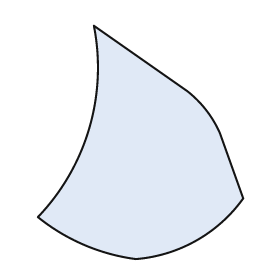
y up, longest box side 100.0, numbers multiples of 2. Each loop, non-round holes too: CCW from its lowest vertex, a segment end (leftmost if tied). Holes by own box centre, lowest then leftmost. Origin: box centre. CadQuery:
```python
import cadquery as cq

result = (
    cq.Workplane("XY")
    .moveTo(-2.0, -50.0)
    .threePointArc((24.0, -42.0), (44.0, -24.0))
    .lineTo(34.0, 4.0)
    .threePointArc((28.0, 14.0), (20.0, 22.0))
    .lineTo(-20.0, 50.0)
    .threePointArc((-22.0, 6.0), (-44.0, -32.0))
    .threePointArc((-24.0, -44.0), (-2.0, -50.0))
    .close()
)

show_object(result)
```